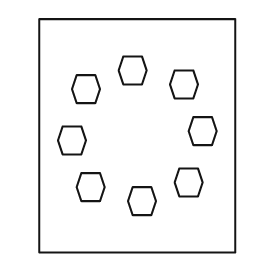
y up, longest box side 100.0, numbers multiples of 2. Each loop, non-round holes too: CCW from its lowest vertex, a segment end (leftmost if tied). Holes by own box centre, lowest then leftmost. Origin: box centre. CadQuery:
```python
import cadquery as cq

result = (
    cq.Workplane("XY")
    .moveTo(-42.0, -50.0)
    .lineTo(42.0, -50.0)
    .lineTo(42.0, 50.0)
    .lineTo(-42.0, 50.0)
    .close()
    .moveTo(-2.0, -34.0)
    .lineTo(6.0, -34.0)
    .lineTo(8.0, -28.0)
    .lineTo(6.0, -22.0)
    .lineTo(-2.0, -22.0)
    .lineTo(-4.0, -28.0)
    .close()
    .moveTo(-24.0, -28.0)
    .lineTo(-16.0, -28.0)
    .lineTo(-14.0, -22.0)
    .lineTo(-16.0, -16.0)
    .lineTo(-24.0, -16.0)
    .lineTo(-26.0, -22.0)
    .close()
    .moveTo(18.0, -26.0)
    .lineTo(26.0, -26.0)
    .lineTo(28.0, -20.0)
    .lineTo(26.0, -14.0)
    .lineTo(18.0, -14.0)
    .lineTo(16.0, -20.0)
    .close()
    .moveTo(-32.0, -8.0)
    .lineTo(-24.0, -8.0)
    .lineTo(-22.0, -2.0)
    .lineTo(-24.0, 4.0)
    .lineTo(-32.0, 4.0)
    .lineTo(-34.0, -2.0)
    .close()
    .moveTo(24.0, -4.0)
    .lineTo(32.0, -4.0)
    .lineTo(34.0, 2.0)
    .lineTo(32.0, 8.0)
    .lineTo(24.0, 8.0)
    .lineTo(22.0, 2.0)
    .close()
    .moveTo(-26.0, 14.0)
    .lineTo(-18.0, 14.0)
    .lineTo(-16.0, 20.0)
    .lineTo(-18.0, 26.0)
    .lineTo(-26.0, 26.0)
    .lineTo(-28.0, 20.0)
    .close()
    .moveTo(16.0, 16.0)
    .lineTo(24.0, 16.0)
    .lineTo(26.0, 22.0)
    .lineTo(24.0, 28.0)
    .lineTo(16.0, 28.0)
    .lineTo(14.0, 22.0)
    .close()
    .moveTo(-6.0, 22.0)
    .lineTo(2.0, 22.0)
    .lineTo(4.0, 28.0)
    .lineTo(2.0, 34.0)
    .lineTo(-6.0, 34.0)
    .lineTo(-8.0, 28.0)
    .close()
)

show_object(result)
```